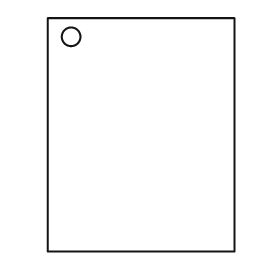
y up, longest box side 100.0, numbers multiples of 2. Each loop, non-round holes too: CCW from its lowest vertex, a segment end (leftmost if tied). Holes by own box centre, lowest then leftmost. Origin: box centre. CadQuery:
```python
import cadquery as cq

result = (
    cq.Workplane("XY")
    .moveTo(-40.0, -50.0)
    .lineTo(40.0, -50.0)
    .lineTo(40.0, 50.0)
    .lineTo(-40.0, 50.0)
    .close()
    .moveTo(-30.0, 42.0)
    .circle(4.0)
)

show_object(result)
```